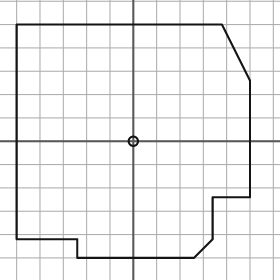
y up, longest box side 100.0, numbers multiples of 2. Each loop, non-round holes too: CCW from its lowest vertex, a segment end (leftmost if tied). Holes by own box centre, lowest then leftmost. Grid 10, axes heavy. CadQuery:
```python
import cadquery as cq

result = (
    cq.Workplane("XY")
    .moveTo(-24.0, -50.0)
    .lineTo(26.0, -50.0)
    .lineTo(34.0, -42.0)
    .lineTo(34.0, -24.0)
    .lineTo(50.0, -24.0)
    .lineTo(50.0, 26.0)
    .lineTo(38.0, 50.0)
    .lineTo(-50.0, 50.0)
    .lineTo(-50.0, -42.0)
    .lineTo(-24.0, -42.0)
    .close()
    .moveTo(0.0, 0.0)
    .circle(2.0)
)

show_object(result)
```